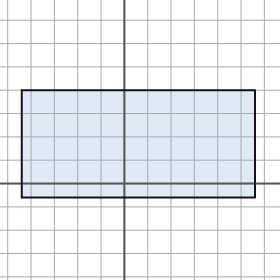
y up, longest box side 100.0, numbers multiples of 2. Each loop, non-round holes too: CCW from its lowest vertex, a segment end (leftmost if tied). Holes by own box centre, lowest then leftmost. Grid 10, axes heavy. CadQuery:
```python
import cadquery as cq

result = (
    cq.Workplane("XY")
    .moveTo(-44.0, -6.0)
    .lineTo(56.0, -6.0)
    .lineTo(56.0, 40.0)
    .lineTo(-44.0, 40.0)
    .close()
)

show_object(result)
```